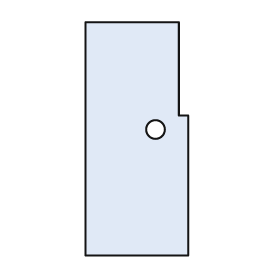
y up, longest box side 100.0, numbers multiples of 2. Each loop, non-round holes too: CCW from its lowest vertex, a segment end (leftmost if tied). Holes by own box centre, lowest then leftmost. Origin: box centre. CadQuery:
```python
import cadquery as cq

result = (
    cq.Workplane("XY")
    .moveTo(-22.0, -50.0)
    .lineTo(22.0, -50.0)
    .lineTo(22.0, 10.0)
    .lineTo(18.0, 10.0)
    .lineTo(18.0, 50.0)
    .lineTo(-22.0, 50.0)
    .close()
    .moveTo(8.0, 4.0)
    .circle(4.0)
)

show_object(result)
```